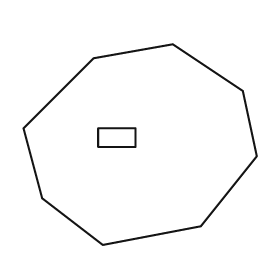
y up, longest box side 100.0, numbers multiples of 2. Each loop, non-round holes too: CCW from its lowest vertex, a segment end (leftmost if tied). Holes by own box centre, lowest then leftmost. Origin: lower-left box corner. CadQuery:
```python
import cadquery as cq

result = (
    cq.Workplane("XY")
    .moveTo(34.0, 0.0)
    .lineTo(76.0, 8.0)
    .lineTo(100.0, 38.0)
    .lineTo(94.0, 66.0)
    .lineTo(64.0, 86.0)
    .lineTo(30.0, 80.0)
    .lineTo(0.0, 50.0)
    .lineTo(8.0, 20.0)
    .close()
    .moveTo(32.0, 42.0)
    .lineTo(48.0, 42.0)
    .lineTo(48.0, 50.0)
    .lineTo(32.0, 50.0)
    .close()
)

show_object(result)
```